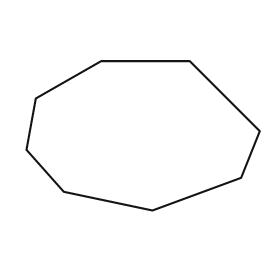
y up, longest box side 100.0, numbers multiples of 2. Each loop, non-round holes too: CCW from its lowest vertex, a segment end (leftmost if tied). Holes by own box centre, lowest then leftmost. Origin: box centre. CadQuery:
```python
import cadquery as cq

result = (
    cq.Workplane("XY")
    .moveTo(4.0, -32.0)
    .lineTo(42.0, -18.0)
    .lineTo(50.0, 2.0)
    .lineTo(20.0, 32.0)
    .lineTo(-18.0, 32.0)
    .lineTo(-46.0, 16.0)
    .lineTo(-50.0, -6.0)
    .lineTo(-34.0, -24.0)
    .close()
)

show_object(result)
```